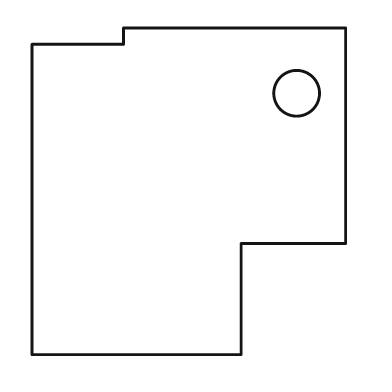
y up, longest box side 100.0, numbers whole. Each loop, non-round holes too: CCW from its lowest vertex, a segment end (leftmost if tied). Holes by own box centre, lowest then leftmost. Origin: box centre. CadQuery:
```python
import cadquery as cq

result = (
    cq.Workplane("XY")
    .moveTo(-48.0, -50.0)
    .lineTo(16.0, -50.0)
    .lineTo(16.0, -16.0)
    .lineTo(48.0, -16.0)
    .lineTo(48.0, 50.0)
    .lineTo(-20.0, 50.0)
    .lineTo(-20.0, 45.0)
    .lineTo(-48.0, 45.0)
    .close()
    .moveTo(33.0, 30.0)
    .circle(7.0)
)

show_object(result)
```